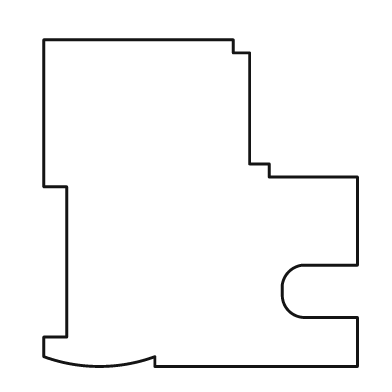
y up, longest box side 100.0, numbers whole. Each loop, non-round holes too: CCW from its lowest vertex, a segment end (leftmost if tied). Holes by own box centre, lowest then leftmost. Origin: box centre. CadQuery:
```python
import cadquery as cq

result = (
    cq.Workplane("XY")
    .moveTo(-14.0, -50.0)
    .lineTo(48.0, -50.0)
    .lineTo(48.0, -35.0)
    .lineTo(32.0, -35.0)
    .threePointArc((27.0, -33.0), (25.0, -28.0))
    .lineTo(25.0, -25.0)
    .threePointArc((27.0, -21.0), (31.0, -19.0))
    .lineTo(48.0, -19.0)
    .lineTo(48.0, 8.0)
    .lineTo(21.0, 8.0)
    .lineTo(21.0, 12.0)
    .lineTo(15.0, 12.0)
    .lineTo(15.0, 46.0)
    .lineTo(10.0, 46.0)
    .lineTo(10.0, 50.0)
    .lineTo(-48.0, 50.0)
    .lineTo(-48.0, 5.0)
    .lineTo(-41.0, 5.0)
    .lineTo(-41.0, -41.0)
    .lineTo(-48.0, -41.0)
    .lineTo(-48.0, -47.0)
    .threePointArc((-31.0, -50.0), (-14.0, -47.0))
    .close()
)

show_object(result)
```